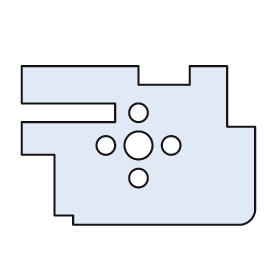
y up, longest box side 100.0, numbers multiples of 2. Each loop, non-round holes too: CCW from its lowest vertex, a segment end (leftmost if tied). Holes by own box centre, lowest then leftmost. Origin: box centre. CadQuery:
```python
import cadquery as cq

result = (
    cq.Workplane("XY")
    .moveTo(-28.0, -34.0)
    .lineTo(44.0, -34.0)
    .threePointArc((48.0, -32.0), (50.0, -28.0))
    .lineTo(50.0, 8.0)
    .lineTo(38.0, 8.0)
    .lineTo(38.0, 34.0)
    .lineTo(22.0, 34.0)
    .lineTo(22.0, 26.0)
    .lineTo(0.0, 26.0)
    .lineTo(0.0, 34.0)
    .lineTo(-50.0, 34.0)
    .lineTo(-50.0, 18.0)
    .lineTo(-10.0, 18.0)
    .lineTo(-10.0, 10.0)
    .lineTo(-50.0, 10.0)
    .lineTo(-50.0, -4.0)
    .lineTo(-36.0, -4.0)
    .lineTo(-36.0, -30.0)
    .lineTo(-28.0, -30.0)
    .close()
    .moveTo(0.0, -14.0)
    .circle(4.0)
    .moveTo(-14.0, 0.0)
    .circle(4.0)
    .moveTo(0.0, 0.0)
    .circle(6.0)
    .moveTo(14.0, 0.0)
    .circle(4.0)
    .moveTo(0.0, 14.0)
    .circle(4.0)
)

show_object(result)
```